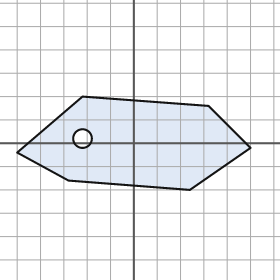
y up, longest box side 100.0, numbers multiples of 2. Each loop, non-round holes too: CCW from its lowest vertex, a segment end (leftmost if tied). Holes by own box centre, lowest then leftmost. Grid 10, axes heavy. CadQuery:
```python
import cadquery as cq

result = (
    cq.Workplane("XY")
    .moveTo(24.0, -20.0)
    .lineTo(50.0, -2.0)
    .lineTo(32.0, 16.0)
    .lineTo(-22.0, 20.0)
    .lineTo(-50.0, -4.0)
    .lineTo(-28.0, -16.0)
    .close()
    .moveTo(-22.0, 2.0)
    .circle(4.0)
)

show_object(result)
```